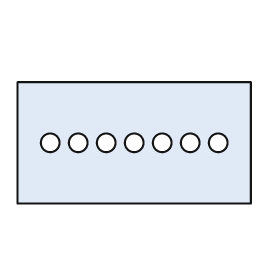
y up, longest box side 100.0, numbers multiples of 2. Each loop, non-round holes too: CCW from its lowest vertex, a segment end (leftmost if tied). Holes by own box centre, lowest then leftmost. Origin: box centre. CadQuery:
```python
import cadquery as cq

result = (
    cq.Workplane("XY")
    .moveTo(-50.0, -26.0)
    .lineTo(50.0, -26.0)
    .lineTo(50.0, 26.0)
    .lineTo(-50.0, 26.0)
    .close()
    .moveTo(-36.0, 0.0)
    .circle(4.0)
    .moveTo(-24.0, 0.0)
    .circle(4.0)
    .moveTo(-12.0, 0.0)
    .circle(4.0)
    .moveTo(0.0, 0.0)
    .circle(4.0)
    .moveTo(12.0, 0.0)
    .circle(4.0)
    .moveTo(24.0, 0.0)
    .circle(4.0)
    .moveTo(36.0, 0.0)
    .circle(4.0)
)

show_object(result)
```